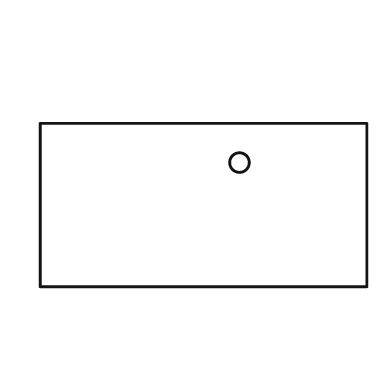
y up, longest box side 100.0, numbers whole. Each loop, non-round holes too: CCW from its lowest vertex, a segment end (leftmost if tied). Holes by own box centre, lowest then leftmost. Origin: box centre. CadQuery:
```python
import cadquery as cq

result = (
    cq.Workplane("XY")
    .moveTo(-50.0, -25.0)
    .lineTo(50.0, -25.0)
    .lineTo(50.0, 25.0)
    .lineTo(-50.0, 25.0)
    .close()
    .moveTo(11.0, 13.0)
    .circle(3.0)
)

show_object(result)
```